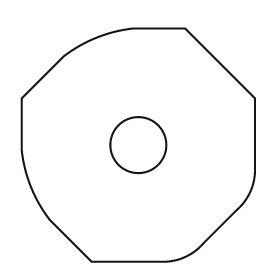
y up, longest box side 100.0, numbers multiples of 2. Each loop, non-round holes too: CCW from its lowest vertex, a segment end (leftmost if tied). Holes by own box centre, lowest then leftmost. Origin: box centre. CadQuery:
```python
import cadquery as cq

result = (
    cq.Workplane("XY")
    .moveTo(-20.0, -50.0)
    .lineTo(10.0, -50.0)
    .threePointArc((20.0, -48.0), (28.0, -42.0))
    .lineTo(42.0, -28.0)
    .threePointArc((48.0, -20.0), (50.0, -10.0))
    .lineTo(50.0, 20.0)
    .lineTo(20.0, 50.0)
    .lineTo(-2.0, 50.0)
    .threePointArc((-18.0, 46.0), (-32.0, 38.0))
    .lineTo(-50.0, 20.0)
    .lineTo(-50.0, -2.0)
    .threePointArc((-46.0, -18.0), (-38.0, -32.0))
    .close()
    .moveTo(0.0, 0.0)
    .circle(12.0)
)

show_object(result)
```